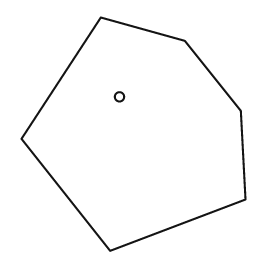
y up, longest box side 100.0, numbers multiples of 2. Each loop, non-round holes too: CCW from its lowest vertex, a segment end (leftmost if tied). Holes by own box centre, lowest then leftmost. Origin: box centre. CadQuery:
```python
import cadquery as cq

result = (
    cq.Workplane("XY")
    .moveTo(-10.0, -50.0)
    .lineTo(48.0, -28.0)
    .lineTo(46.0, 10.0)
    .lineTo(22.0, 40.0)
    .lineTo(-14.0, 50.0)
    .lineTo(-48.0, -2.0)
    .close()
    .moveTo(-6.0, 16.0)
    .circle(2.0)
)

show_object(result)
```